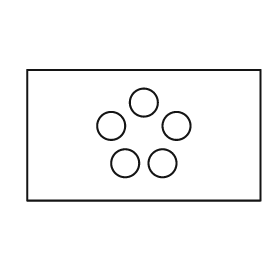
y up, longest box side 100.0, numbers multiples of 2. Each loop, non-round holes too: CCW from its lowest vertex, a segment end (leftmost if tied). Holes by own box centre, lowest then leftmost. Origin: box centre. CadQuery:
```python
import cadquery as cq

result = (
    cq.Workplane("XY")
    .moveTo(-50.0, -28.0)
    .lineTo(50.0, -28.0)
    .lineTo(50.0, 28.0)
    .lineTo(-50.0, 28.0)
    .close()
    .moveTo(-8.0, -12.0)
    .circle(6.0)
    .moveTo(8.0, -12.0)
    .circle(6.0)
    .moveTo(-14.0, 4.0)
    .circle(6.0)
    .moveTo(14.0, 4.0)
    .circle(6.0)
    .moveTo(0.0, 14.0)
    .circle(6.0)
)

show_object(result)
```